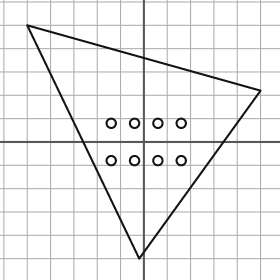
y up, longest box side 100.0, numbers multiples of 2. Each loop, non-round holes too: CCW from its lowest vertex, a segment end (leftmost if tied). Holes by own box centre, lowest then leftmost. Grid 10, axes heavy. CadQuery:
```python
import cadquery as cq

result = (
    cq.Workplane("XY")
    .moveTo(-2.0, -50.0)
    .lineTo(50.0, 22.0)
    .lineTo(-50.0, 50.0)
    .close()
    .moveTo(-14.0, -8.0)
    .circle(2.0)
    .moveTo(-4.0, -8.0)
    .circle(2.0)
    .moveTo(6.0, -8.0)
    .circle(2.0)
    .moveTo(16.0, -8.0)
    .circle(2.0)
    .moveTo(-14.0, 8.0)
    .circle(2.0)
    .moveTo(-4.0, 8.0)
    .circle(2.0)
    .moveTo(6.0, 8.0)
    .circle(2.0)
    .moveTo(16.0, 8.0)
    .circle(2.0)
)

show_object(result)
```